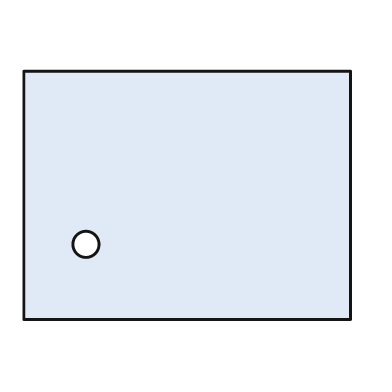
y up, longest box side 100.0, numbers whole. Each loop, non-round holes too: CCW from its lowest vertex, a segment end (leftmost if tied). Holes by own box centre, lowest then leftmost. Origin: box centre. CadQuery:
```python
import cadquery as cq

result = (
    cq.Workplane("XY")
    .moveTo(-50.0, -38.0)
    .lineTo(50.0, -38.0)
    .lineTo(50.0, 38.0)
    .lineTo(-50.0, 38.0)
    .close()
    .moveTo(-31.0, -15.0)
    .circle(4.0)
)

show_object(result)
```